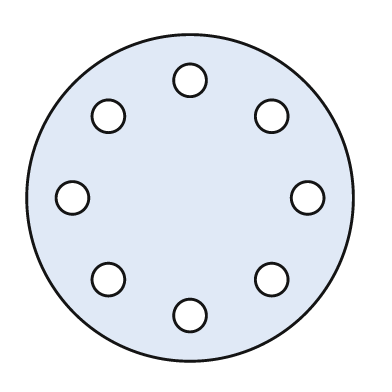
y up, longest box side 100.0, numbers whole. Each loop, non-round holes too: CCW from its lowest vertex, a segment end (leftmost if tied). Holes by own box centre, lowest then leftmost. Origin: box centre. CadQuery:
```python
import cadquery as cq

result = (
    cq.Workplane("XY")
    .moveTo(0.0, 0.0)
    .circle(50.0)
    .moveTo(0.0, -36.0)
    .circle(5.0)
    .moveTo(-25.0, -25.0)
    .circle(5.0)
    .moveTo(25.0, -25.0)
    .circle(5.0)
    .moveTo(-36.0, 0.0)
    .circle(5.0)
    .moveTo(36.0, 0.0)
    .circle(5.0)
    .moveTo(-25.0, 25.0)
    .circle(5.0)
    .moveTo(25.0, 25.0)
    .circle(5.0)
    .moveTo(0.0, 36.0)
    .circle(5.0)
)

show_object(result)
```